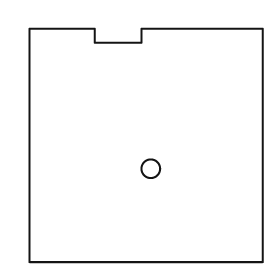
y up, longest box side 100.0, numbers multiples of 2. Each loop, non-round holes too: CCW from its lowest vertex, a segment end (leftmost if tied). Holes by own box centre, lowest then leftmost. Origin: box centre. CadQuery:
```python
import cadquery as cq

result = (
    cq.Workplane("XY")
    .moveTo(-50.0, -50.0)
    .lineTo(50.0, -50.0)
    .lineTo(50.0, 50.0)
    .lineTo(-2.0, 50.0)
    .lineTo(-2.0, 44.0)
    .lineTo(-22.0, 44.0)
    .lineTo(-22.0, 50.0)
    .lineTo(-50.0, 50.0)
    .close()
    .moveTo(2.0, -10.0)
    .circle(4.0)
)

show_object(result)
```